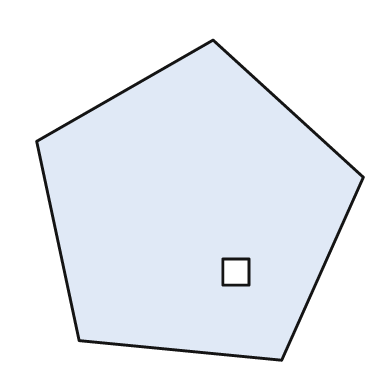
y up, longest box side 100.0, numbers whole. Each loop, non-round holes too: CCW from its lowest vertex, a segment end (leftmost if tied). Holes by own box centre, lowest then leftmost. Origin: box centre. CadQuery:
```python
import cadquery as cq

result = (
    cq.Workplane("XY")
    .moveTo(25.0, -49.0)
    .lineTo(50.0, 7.0)
    .lineTo(4.0, 49.0)
    .lineTo(-50.0, 18.0)
    .lineTo(-37.0, -43.0)
    .close()
    .moveTo(7.0, -26.0)
    .lineTo(15.0, -26.0)
    .lineTo(15.0, -18.0)
    .lineTo(7.0, -18.0)
    .close()
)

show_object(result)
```